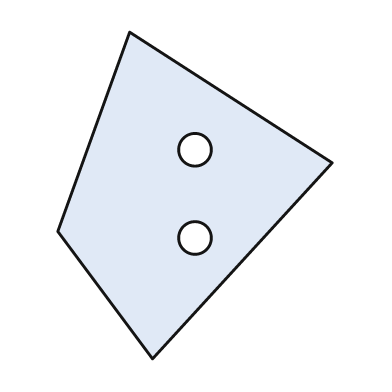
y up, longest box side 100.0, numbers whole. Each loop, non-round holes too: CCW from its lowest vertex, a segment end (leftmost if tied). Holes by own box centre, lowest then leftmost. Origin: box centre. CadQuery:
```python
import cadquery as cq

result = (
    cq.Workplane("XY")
    .moveTo(-13.0, -50.0)
    .lineTo(42.0, 10.0)
    .lineTo(-20.0, 50.0)
    .lineTo(-42.0, -11.0)
    .close()
    .moveTo(0.0, -13.0)
    .circle(5.0)
    .moveTo(0.0, 14.0)
    .circle(5.0)
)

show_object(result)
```